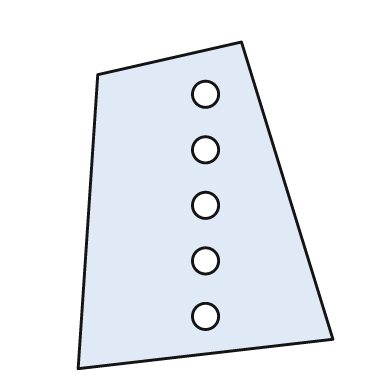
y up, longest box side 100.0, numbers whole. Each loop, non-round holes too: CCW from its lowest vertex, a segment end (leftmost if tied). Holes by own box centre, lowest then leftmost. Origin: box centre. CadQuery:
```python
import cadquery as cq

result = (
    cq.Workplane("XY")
    .moveTo(-39.0, -50.0)
    .lineTo(39.0, -41.0)
    .lineTo(11.0, 50.0)
    .lineTo(-33.0, 40.0)
    .close()
    .moveTo(0.0, -34.0)
    .circle(4.0)
    .moveTo(0.0, -17.0)
    .circle(4.0)
    .moveTo(0.0, 0.0)
    .circle(4.0)
    .moveTo(0.0, 17.0)
    .circle(4.0)
    .moveTo(0.0, 34.0)
    .circle(4.0)
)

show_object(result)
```